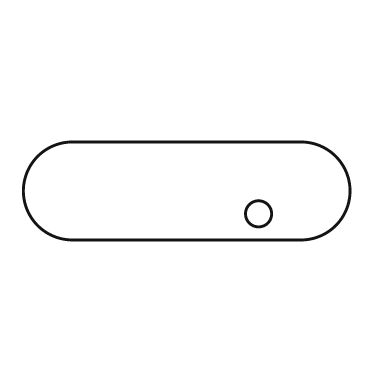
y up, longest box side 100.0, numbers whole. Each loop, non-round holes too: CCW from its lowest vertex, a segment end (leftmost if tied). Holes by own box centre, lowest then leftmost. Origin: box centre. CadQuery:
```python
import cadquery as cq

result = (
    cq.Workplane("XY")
    .moveTo(-35.0, -15.0)
    .lineTo(35.0, -15.0)
    .threePointArc((50.0, 0.0), (35.0, 15.0))
    .lineTo(-35.0, 15.0)
    .threePointArc((-50.0, 0.0), (-35.0, -15.0))
    .close()
    .moveTo(22.0, -7.0)
    .circle(4.0)
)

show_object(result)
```